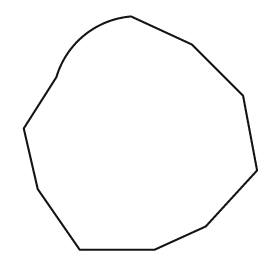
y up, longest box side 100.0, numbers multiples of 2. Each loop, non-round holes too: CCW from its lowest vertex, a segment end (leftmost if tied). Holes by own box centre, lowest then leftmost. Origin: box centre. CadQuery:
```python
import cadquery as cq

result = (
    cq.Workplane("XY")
    .moveTo(-26.0, -50.0)
    .lineTo(6.0, -50.0)
    .lineTo(28.0, -40.0)
    .lineTo(50.0, -16.0)
    .lineTo(44.0, 16.0)
    .lineTo(22.0, 38.0)
    .lineTo(-4.0, 50.0)
    .threePointArc((-24.0, 42.0), (-36.0, 24.0))
    .lineTo(-50.0, 2.0)
    .lineTo(-44.0, -24.0)
    .close()
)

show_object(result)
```